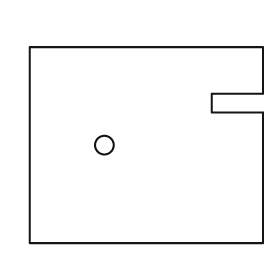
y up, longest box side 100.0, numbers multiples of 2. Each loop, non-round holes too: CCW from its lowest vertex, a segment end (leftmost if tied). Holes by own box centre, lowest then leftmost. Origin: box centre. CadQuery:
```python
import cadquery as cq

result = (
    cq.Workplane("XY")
    .moveTo(-50.0, -42.0)
    .lineTo(50.0, -42.0)
    .lineTo(50.0, 14.0)
    .lineTo(28.0, 14.0)
    .lineTo(28.0, 22.0)
    .lineTo(50.0, 22.0)
    .lineTo(50.0, 42.0)
    .lineTo(-50.0, 42.0)
    .close()
    .moveTo(-18.0, 0.0)
    .circle(4.0)
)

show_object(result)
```